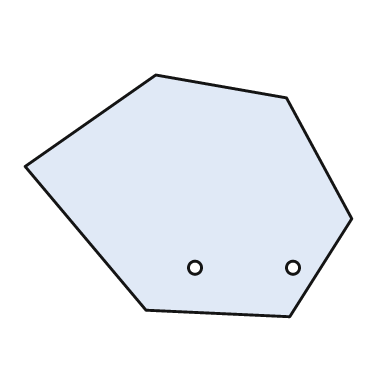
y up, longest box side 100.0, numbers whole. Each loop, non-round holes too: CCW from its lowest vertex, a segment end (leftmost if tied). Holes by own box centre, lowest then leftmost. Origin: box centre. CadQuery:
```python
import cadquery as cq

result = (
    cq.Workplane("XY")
    .moveTo(31.0, -37.0)
    .lineTo(50.0, -7.0)
    .lineTo(30.0, 30.0)
    .lineTo(-10.0, 37.0)
    .lineTo(-50.0, 9.0)
    .lineTo(-13.0, -35.0)
    .close()
    .moveTo(2.0, -22.0)
    .circle(2.0)
    .moveTo(32.0, -22.0)
    .circle(2.0)
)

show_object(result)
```